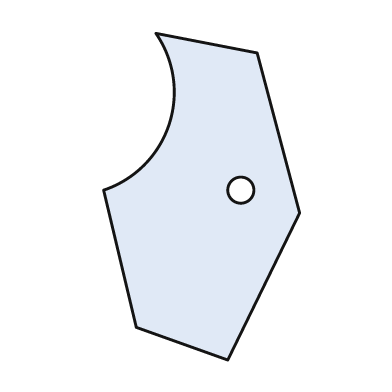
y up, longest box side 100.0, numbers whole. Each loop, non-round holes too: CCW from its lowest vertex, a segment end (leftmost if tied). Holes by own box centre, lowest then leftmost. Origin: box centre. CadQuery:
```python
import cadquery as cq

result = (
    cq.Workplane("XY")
    .moveTo(8.0, -50.0)
    .lineTo(30.0, -5.0)
    .lineTo(17.0, 44.0)
    .lineTo(-14.0, 50.0)
    .threePointArc((-10.0, 22.0), (-30.0, 2.0))
    .lineTo(-20.0, -40.0)
    .close()
    .moveTo(12.0, 2.0)
    .circle(4.0)
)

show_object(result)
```